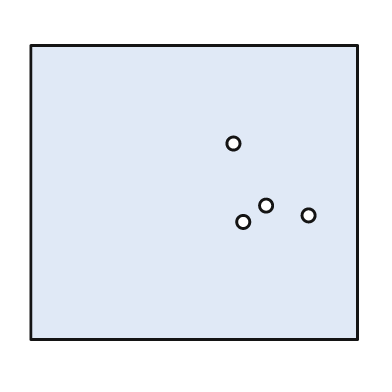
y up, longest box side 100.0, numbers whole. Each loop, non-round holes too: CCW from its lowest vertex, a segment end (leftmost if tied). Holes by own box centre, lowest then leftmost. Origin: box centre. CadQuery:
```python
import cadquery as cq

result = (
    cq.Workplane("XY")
    .moveTo(-50.0, -45.0)
    .lineTo(50.0, -45.0)
    .lineTo(50.0, 45.0)
    .lineTo(-50.0, 45.0)
    .close()
    .moveTo(15.0, -9.0)
    .circle(2.0)
    .moveTo(35.0, -7.0)
    .circle(2.0)
    .moveTo(22.0, -4.0)
    .circle(2.0)
    .moveTo(12.0, 15.0)
    .circle(2.0)
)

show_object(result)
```